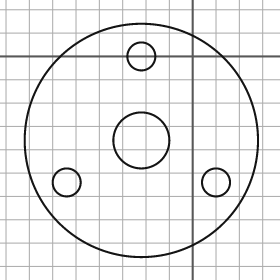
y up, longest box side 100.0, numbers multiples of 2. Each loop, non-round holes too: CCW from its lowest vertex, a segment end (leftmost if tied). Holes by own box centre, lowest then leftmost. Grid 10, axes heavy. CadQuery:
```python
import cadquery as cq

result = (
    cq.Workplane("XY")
    .moveTo(-22.0, -36.0)
    .circle(50.0)
    .moveTo(-54.0, -54.0)
    .circle(6.0)
    .moveTo(10.0, -54.0)
    .circle(6.0)
    .moveTo(-22.0, -36.0)
    .circle(12.0)
    .moveTo(-22.0, 0.0)
    .circle(6.0)
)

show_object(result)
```